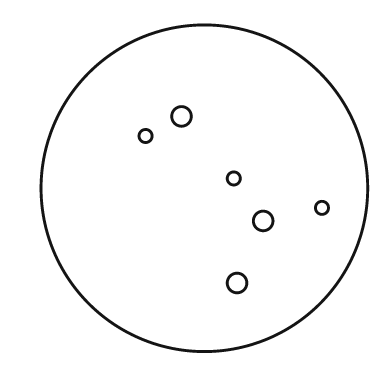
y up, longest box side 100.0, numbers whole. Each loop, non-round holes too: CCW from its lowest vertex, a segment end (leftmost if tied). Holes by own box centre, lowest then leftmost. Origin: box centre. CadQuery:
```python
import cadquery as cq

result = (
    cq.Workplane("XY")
    .moveTo(0.0, 0.0)
    .circle(50.0)
    .moveTo(10.0, -29.0)
    .circle(3.0)
    .moveTo(18.0, -10.0)
    .circle(3.0)
    .moveTo(36.0, -6.0)
    .circle(2.0)
    .moveTo(9.0, 3.0)
    .circle(2.0)
    .moveTo(-18.0, 16.0)
    .circle(2.0)
    .moveTo(-7.0, 22.0)
    .circle(3.0)
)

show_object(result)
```